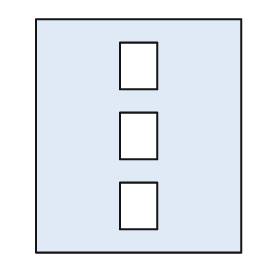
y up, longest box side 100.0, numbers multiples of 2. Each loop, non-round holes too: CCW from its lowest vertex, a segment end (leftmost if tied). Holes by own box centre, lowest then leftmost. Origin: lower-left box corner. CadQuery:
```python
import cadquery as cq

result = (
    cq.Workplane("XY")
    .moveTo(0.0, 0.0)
    .lineTo(88.0, 0.0)
    .lineTo(88.0, 100.0)
    .lineTo(0.0, 100.0)
    .close()
    .moveTo(36.0, 10.0)
    .lineTo(52.0, 10.0)
    .lineTo(52.0, 30.0)
    .lineTo(36.0, 30.0)
    .close()
    .moveTo(36.0, 40.0)
    .lineTo(52.0, 40.0)
    .lineTo(52.0, 60.0)
    .lineTo(36.0, 60.0)
    .close()
    .moveTo(36.0, 70.0)
    .lineTo(52.0, 70.0)
    .lineTo(52.0, 90.0)
    .lineTo(36.0, 90.0)
    .close()
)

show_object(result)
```